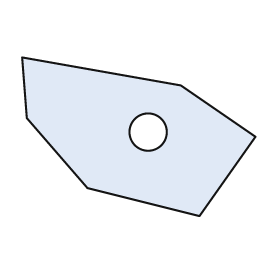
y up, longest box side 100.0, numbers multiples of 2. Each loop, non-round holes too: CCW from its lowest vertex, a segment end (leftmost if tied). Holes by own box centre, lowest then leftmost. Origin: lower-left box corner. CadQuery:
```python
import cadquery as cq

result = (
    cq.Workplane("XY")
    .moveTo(76.0, 0.0)
    .lineTo(100.0, 34.0)
    .lineTo(68.0, 56.0)
    .lineTo(0.0, 68.0)
    .lineTo(2.0, 42.0)
    .lineTo(28.0, 12.0)
    .close()
    .moveTo(54.0, 36.0)
    .circle(8.0)
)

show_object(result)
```